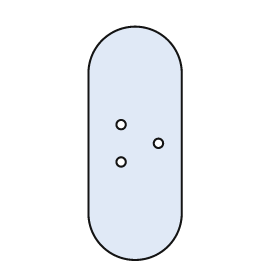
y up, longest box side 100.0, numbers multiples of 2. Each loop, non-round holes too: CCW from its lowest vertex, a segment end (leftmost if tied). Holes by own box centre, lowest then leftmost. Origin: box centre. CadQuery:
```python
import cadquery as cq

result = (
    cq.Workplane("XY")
    .moveTo(-20.0, -30.0)
    .threePointArc((0.0, -50.0), (20.0, -30.0))
    .lineTo(20.0, 30.0)
    .threePointArc((0.0, 50.0), (-20.0, 30.0))
    .close()
    .moveTo(-6.0, -8.0)
    .circle(2.0)
    .moveTo(10.0, 0.0)
    .circle(2.0)
    .moveTo(-6.0, 8.0)
    .circle(2.0)
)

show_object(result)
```